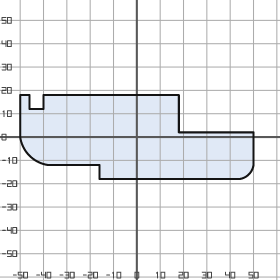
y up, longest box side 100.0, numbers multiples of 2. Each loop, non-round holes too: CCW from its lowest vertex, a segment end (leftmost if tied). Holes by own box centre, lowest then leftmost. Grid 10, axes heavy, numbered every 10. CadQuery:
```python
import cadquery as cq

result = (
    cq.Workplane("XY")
    .moveTo(-16.0, -18.0)
    .lineTo(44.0, -18.0)
    .threePointArc((48.0, -16.0), (50.0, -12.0))
    .lineTo(50.0, 2.0)
    .lineTo(18.0, 2.0)
    .lineTo(18.0, 18.0)
    .lineTo(-40.0, 18.0)
    .lineTo(-40.0, 12.0)
    .lineTo(-46.0, 12.0)
    .lineTo(-46.0, 18.0)
    .lineTo(-50.0, 18.0)
    .lineTo(-50.0, 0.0)
    .threePointArc((-46.0, -8.0), (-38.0, -12.0))
    .lineTo(-16.0, -12.0)
    .close()
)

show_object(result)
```